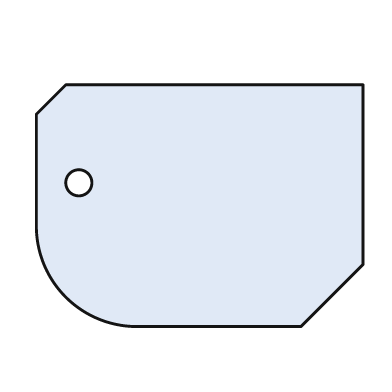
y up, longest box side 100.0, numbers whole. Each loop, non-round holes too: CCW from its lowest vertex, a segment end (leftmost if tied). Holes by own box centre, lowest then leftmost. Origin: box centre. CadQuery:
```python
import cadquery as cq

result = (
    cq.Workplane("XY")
    .moveTo(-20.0, -37.0)
    .lineTo(31.0, -37.0)
    .lineTo(50.0, -18.0)
    .lineTo(50.0, 37.0)
    .lineTo(-41.0, 37.0)
    .lineTo(-50.0, 28.0)
    .lineTo(-50.0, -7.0)
    .threePointArc((-41.0, -28.0), (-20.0, -37.0))
    .close()
    .moveTo(-37.0, 7.0)
    .circle(4.0)
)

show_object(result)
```